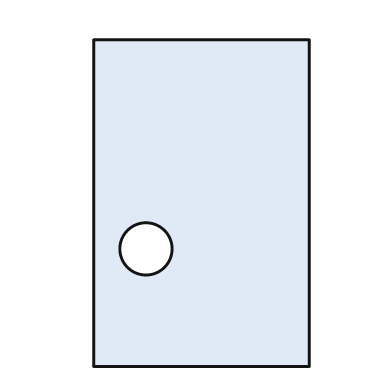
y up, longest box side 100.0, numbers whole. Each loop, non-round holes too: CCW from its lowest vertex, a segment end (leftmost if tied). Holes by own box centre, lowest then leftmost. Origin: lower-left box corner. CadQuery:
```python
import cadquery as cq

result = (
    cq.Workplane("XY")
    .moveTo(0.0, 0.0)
    .lineTo(66.0, 0.0)
    .lineTo(66.0, 100.0)
    .lineTo(0.0, 100.0)
    .close()
    .moveTo(16.0, 36.0)
    .circle(8.0)
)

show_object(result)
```